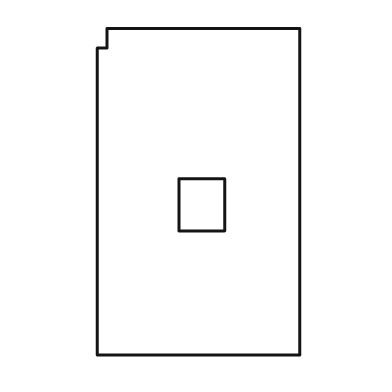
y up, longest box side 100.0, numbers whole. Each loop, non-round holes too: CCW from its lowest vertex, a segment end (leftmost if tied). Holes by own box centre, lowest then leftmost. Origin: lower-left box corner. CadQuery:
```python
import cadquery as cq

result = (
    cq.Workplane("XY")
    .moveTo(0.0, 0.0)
    .lineTo(62.0, 0.0)
    .lineTo(62.0, 100.0)
    .lineTo(3.0, 100.0)
    .lineTo(3.0, 94.0)
    .lineTo(0.0, 94.0)
    .close()
    .moveTo(25.0, 38.0)
    .lineTo(39.0, 38.0)
    .lineTo(39.0, 54.0)
    .lineTo(25.0, 54.0)
    .close()
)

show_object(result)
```